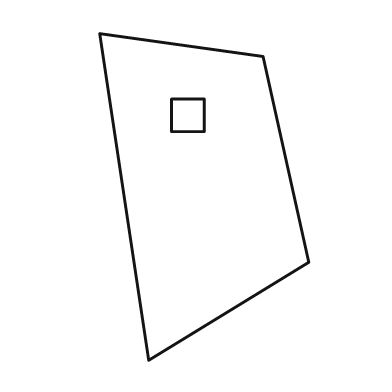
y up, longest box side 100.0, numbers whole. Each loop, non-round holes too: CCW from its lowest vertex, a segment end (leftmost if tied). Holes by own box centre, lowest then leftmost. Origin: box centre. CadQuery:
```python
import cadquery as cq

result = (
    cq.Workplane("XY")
    .moveTo(-17.0, -50.0)
    .lineTo(32.0, -20.0)
    .lineTo(18.0, 43.0)
    .lineTo(-32.0, 50.0)
    .close()
    .moveTo(-10.0, 20.0)
    .lineTo(0.0, 20.0)
    .lineTo(0.0, 30.0)
    .lineTo(-10.0, 30.0)
    .close()
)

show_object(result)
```